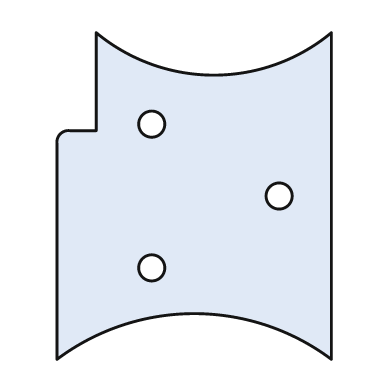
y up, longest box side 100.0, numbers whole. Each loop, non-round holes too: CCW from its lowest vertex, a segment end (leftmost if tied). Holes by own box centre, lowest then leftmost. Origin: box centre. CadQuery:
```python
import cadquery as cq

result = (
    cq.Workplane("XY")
    .moveTo(-42.0, -50.0)
    .threePointArc((0.0, -36.0), (42.0, -50.0))
    .lineTo(42.0, 50.0)
    .threePointArc((6.0, 37.0), (-30.0, 50.0))
    .lineTo(-30.0, 20.0)
    .lineTo(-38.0, 20.0)
    .threePointArc((-41.0, 19.0), (-42.0, 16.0))
    .close()
    .moveTo(-13.0, -22.0)
    .circle(4.0)
    .moveTo(26.0, 0.0)
    .circle(4.0)
    .moveTo(-13.0, 22.0)
    .circle(4.0)
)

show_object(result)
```